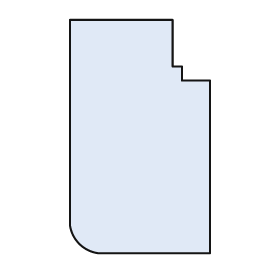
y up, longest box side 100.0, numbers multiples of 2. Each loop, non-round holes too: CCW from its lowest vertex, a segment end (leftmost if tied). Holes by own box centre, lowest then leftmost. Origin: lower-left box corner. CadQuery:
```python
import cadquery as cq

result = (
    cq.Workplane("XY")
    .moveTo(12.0, 0.0)
    .lineTo(60.0, 0.0)
    .lineTo(60.0, 74.0)
    .lineTo(48.0, 74.0)
    .lineTo(48.0, 80.0)
    .lineTo(44.0, 80.0)
    .lineTo(44.0, 100.0)
    .lineTo(0.0, 100.0)
    .lineTo(0.0, 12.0)
    .threePointArc((4.0, 4.0), (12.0, 0.0))
    .close()
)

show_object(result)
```